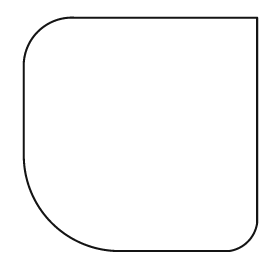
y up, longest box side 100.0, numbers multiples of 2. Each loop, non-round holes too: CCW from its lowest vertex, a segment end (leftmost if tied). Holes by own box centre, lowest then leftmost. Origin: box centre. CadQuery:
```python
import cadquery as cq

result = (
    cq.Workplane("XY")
    .moveTo(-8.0, -50.0)
    .lineTo(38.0, -50.0)
    .threePointArc((46.0, -46.0), (50.0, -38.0))
    .lineTo(50.0, 50.0)
    .lineTo(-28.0, 50.0)
    .threePointArc((-44.0, 44.0), (-50.0, 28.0))
    .lineTo(-50.0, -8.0)
    .threePointArc((-38.0, -38.0), (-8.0, -50.0))
    .close()
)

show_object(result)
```